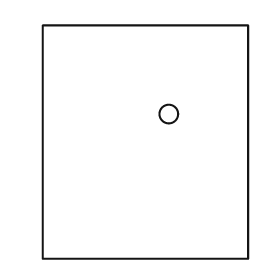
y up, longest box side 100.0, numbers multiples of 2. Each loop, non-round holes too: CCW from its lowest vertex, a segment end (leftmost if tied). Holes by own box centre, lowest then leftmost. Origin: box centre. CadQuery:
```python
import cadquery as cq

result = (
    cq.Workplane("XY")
    .moveTo(-44.0, -50.0)
    .lineTo(44.0, -50.0)
    .lineTo(44.0, 50.0)
    .lineTo(-44.0, 50.0)
    .close()
    .moveTo(10.0, 12.0)
    .circle(4.0)
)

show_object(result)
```